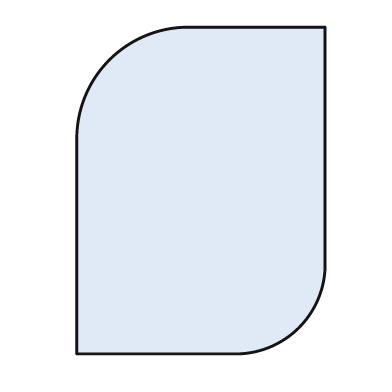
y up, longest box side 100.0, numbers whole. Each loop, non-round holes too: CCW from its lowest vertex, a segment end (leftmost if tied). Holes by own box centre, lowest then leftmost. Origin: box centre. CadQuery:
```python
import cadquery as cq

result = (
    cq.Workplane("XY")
    .moveTo(-38.0, -50.0)
    .lineTo(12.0, -50.0)
    .threePointArc((30.0, -42.0), (38.0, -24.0))
    .lineTo(38.0, 50.0)
    .lineTo(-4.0, 50.0)
    .threePointArc((-28.0, 40.0), (-38.0, 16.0))
    .close()
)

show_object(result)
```